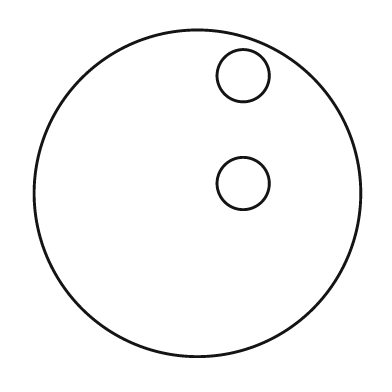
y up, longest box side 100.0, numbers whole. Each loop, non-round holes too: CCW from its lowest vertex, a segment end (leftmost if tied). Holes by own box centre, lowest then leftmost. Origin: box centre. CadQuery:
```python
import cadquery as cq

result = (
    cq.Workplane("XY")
    .moveTo(0.0, 0.0)
    .circle(50.0)
    .moveTo(14.0, 3.0)
    .circle(8.0)
    .moveTo(14.0, 36.0)
    .circle(8.0)
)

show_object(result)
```